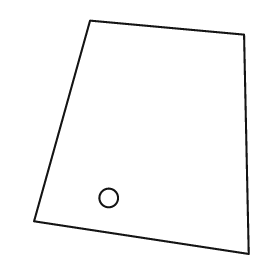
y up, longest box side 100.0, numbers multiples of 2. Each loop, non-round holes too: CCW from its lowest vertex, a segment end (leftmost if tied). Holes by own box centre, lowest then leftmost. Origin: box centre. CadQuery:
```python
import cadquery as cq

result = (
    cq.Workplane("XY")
    .moveTo(46.0, -50.0)
    .lineTo(44.0, 44.0)
    .lineTo(-22.0, 50.0)
    .lineTo(-46.0, -36.0)
    .close()
    .moveTo(-14.0, -26.0)
    .circle(4.0)
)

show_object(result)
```